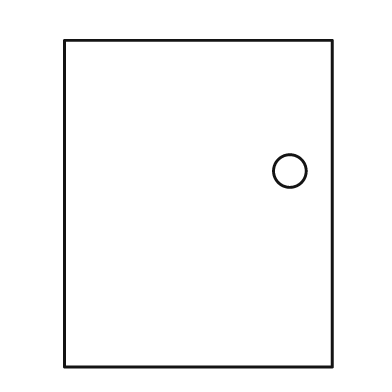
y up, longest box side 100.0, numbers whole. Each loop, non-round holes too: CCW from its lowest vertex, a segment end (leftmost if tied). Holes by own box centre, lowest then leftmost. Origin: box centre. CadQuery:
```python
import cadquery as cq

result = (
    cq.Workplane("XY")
    .moveTo(-41.0, -50.0)
    .lineTo(41.0, -50.0)
    .lineTo(41.0, 50.0)
    .lineTo(-41.0, 50.0)
    .close()
    .moveTo(28.0, 10.0)
    .circle(5.0)
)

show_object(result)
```